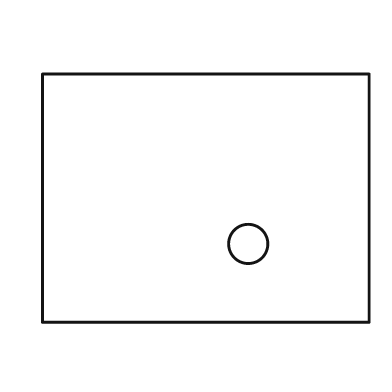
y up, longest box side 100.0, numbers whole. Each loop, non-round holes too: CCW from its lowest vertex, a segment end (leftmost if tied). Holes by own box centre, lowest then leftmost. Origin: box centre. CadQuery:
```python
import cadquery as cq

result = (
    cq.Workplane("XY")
    .moveTo(-50.0, -38.0)
    .lineTo(50.0, -38.0)
    .lineTo(50.0, 38.0)
    .lineTo(-50.0, 38.0)
    .close()
    .moveTo(13.0, -14.0)
    .circle(6.0)
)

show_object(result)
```